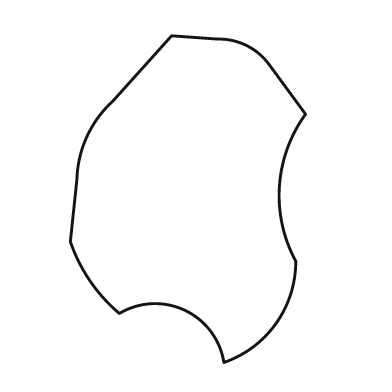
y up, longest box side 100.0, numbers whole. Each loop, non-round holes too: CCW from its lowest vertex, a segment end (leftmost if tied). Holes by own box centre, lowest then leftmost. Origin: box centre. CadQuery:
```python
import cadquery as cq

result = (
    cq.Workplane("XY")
    .moveTo(11.0, -50.0)
    .threePointArc((27.0, -38.0), (33.0, -19.0))
    .threePointArc((28.0, 4.0), (36.0, 26.0))
    .lineTo(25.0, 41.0)
    .threePointArc((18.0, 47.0), (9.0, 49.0))
    .lineTo(-5.0, 50.0)
    .lineTo(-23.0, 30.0)
    .threePointArc((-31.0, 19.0), (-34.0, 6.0))
    .lineTo(-36.0, -13.0)
    .threePointArc((-30.0, -25.0), (-21.0, -35.0))
    .threePointArc((-1.0, -34.0), (11.0, -50.0))
    .close()
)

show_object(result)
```